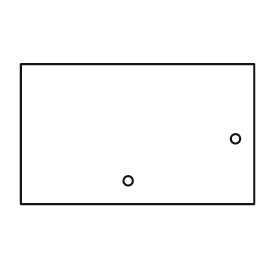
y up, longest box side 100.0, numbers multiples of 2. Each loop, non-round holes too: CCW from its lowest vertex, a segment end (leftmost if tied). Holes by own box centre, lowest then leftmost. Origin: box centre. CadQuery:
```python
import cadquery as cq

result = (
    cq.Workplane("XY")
    .moveTo(-50.0, -30.0)
    .lineTo(50.0, -30.0)
    .lineTo(50.0, 30.0)
    .lineTo(-50.0, 30.0)
    .close()
    .moveTo(-4.0, -20.0)
    .circle(2.0)
    .moveTo(42.0, -2.0)
    .circle(2.0)
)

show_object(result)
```